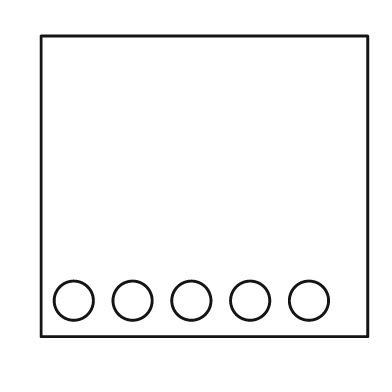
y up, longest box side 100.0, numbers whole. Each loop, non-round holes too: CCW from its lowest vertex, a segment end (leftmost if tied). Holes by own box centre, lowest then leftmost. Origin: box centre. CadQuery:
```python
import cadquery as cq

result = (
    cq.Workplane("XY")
    .moveTo(-50.0, -46.0)
    .lineTo(50.0, -46.0)
    .lineTo(50.0, 46.0)
    .lineTo(-50.0, 46.0)
    .close()
    .moveTo(-40.0, -35.0)
    .circle(6.0)
    .moveTo(-22.0, -35.0)
    .circle(6.0)
    .moveTo(-4.0, -35.0)
    .circle(6.0)
    .moveTo(14.0, -35.0)
    .circle(6.0)
    .moveTo(32.0, -35.0)
    .circle(6.0)
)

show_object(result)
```